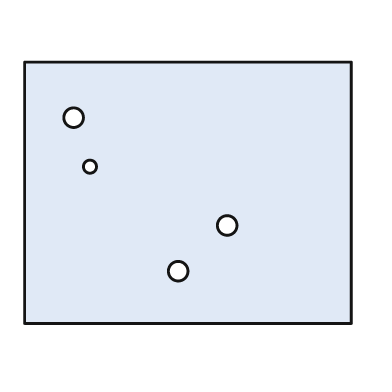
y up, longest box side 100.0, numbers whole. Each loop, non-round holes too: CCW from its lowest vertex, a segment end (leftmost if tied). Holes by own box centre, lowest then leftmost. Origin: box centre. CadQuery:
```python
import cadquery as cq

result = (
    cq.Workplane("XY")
    .moveTo(-50.0, -40.0)
    .lineTo(50.0, -40.0)
    .lineTo(50.0, 40.0)
    .lineTo(-50.0, 40.0)
    .close()
    .moveTo(-3.0, -24.0)
    .circle(3.0)
    .moveTo(12.0, -10.0)
    .circle(3.0)
    .moveTo(-30.0, 8.0)
    .circle(2.0)
    .moveTo(-35.0, 23.0)
    .circle(3.0)
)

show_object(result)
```